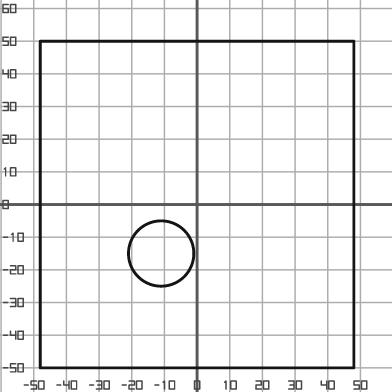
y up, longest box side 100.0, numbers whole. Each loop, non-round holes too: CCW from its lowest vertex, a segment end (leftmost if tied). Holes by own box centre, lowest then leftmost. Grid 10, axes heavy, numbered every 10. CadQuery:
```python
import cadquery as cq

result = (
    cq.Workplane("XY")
    .moveTo(-48.0, -50.0)
    .lineTo(48.0, -50.0)
    .lineTo(48.0, 50.0)
    .lineTo(-48.0, 50.0)
    .close()
    .moveTo(-11.0, -15.0)
    .circle(10.0)
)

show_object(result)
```